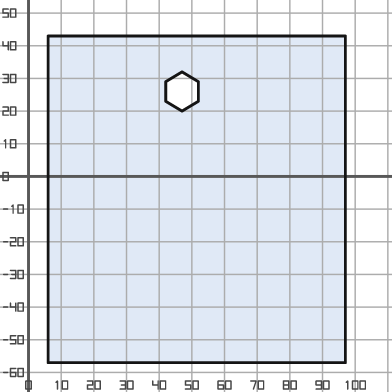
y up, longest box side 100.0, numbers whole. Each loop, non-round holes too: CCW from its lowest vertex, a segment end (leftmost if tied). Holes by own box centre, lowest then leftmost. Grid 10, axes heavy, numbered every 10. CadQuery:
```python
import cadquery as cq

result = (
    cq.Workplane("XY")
    .moveTo(6.0, -57.0)
    .lineTo(97.0, -57.0)
    .lineTo(97.0, 43.0)
    .lineTo(6.0, 43.0)
    .close()
    .moveTo(47.0, 20.0)
    .lineTo(52.0, 23.0)
    .lineTo(52.0, 29.0)
    .lineTo(47.0, 32.0)
    .lineTo(42.0, 29.0)
    .lineTo(42.0, 23.0)
    .close()
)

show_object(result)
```